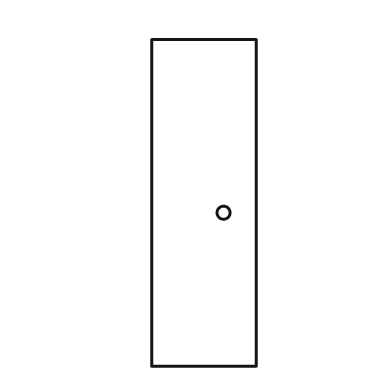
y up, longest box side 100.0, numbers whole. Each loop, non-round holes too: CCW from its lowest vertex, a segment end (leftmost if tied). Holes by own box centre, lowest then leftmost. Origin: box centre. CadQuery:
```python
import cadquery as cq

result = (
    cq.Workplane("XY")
    .moveTo(-16.0, -50.0)
    .lineTo(16.0, -50.0)
    .lineTo(16.0, 50.0)
    .lineTo(-16.0, 50.0)
    .close()
    .moveTo(6.0, -3.0)
    .circle(2.0)
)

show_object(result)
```